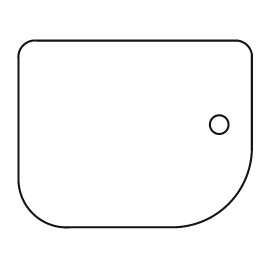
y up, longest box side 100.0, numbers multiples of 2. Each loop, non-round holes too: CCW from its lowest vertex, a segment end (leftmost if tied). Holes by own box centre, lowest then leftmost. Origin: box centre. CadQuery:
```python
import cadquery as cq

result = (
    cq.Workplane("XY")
    .moveTo(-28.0, -40.0)
    .lineTo(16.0, -40.0)
    .threePointArc((40.0, -30.0), (50.0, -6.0))
    .lineTo(50.0, 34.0)
    .threePointArc((48.0, 38.0), (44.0, 40.0))
    .lineTo(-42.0, 40.0)
    .threePointArc((-48.0, 38.0), (-50.0, 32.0))
    .lineTo(-50.0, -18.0)
    .threePointArc((-44.0, -34.0), (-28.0, -40.0))
    .close()
    .moveTo(36.0, 4.0)
    .circle(4.0)
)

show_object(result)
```